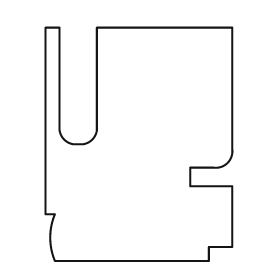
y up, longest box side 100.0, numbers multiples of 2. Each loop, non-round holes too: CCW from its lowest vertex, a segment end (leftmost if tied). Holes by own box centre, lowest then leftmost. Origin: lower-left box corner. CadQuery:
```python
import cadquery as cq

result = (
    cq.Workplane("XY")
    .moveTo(4.0, 0.0)
    .lineTo(70.0, 0.0)
    .lineTo(70.0, 6.0)
    .lineTo(80.0, 6.0)
    .lineTo(80.0, 32.0)
    .lineTo(62.0, 32.0)
    .lineTo(62.0, 40.0)
    .lineTo(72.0, 40.0)
    .threePointArc((78.0, 42.0), (80.0, 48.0))
    .lineTo(80.0, 100.0)
    .lineTo(22.0, 100.0)
    .lineTo(22.0, 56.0)
    .threePointArc((20.0, 52.0), (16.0, 50.0))
    .lineTo(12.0, 50.0)
    .threePointArc((8.0, 52.0), (6.0, 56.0))
    .lineTo(6.0, 100.0)
    .lineTo(0.0, 100.0)
    .lineTo(0.0, 20.0)
    .lineTo(4.0, 20.0)
    .threePointArc((2.0, 10.0), (4.0, 0.0))
    .close()
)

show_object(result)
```